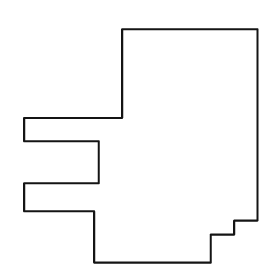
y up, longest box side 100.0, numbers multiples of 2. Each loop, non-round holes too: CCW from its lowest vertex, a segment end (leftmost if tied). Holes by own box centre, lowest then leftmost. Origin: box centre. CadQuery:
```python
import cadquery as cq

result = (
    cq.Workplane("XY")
    .moveTo(-20.0, -50.0)
    .lineTo(30.0, -50.0)
    .lineTo(30.0, -38.0)
    .lineTo(40.0, -38.0)
    .lineTo(40.0, -32.0)
    .lineTo(50.0, -32.0)
    .lineTo(50.0, 50.0)
    .lineTo(-8.0, 50.0)
    .lineTo(-8.0, 12.0)
    .lineTo(-50.0, 12.0)
    .lineTo(-50.0, 2.0)
    .lineTo(-18.0, 2.0)
    .lineTo(-18.0, -16.0)
    .lineTo(-50.0, -16.0)
    .lineTo(-50.0, -28.0)
    .lineTo(-20.0, -28.0)
    .close()
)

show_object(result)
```